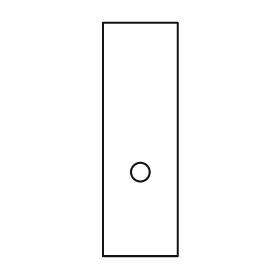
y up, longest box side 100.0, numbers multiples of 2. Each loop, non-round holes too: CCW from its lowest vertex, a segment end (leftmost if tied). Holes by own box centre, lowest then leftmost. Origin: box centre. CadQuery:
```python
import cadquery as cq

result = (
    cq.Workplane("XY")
    .moveTo(-16.0, -50.0)
    .lineTo(16.0, -50.0)
    .lineTo(16.0, 50.0)
    .lineTo(-16.0, 50.0)
    .close()
    .moveTo(0.0, -14.0)
    .circle(4.0)
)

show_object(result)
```